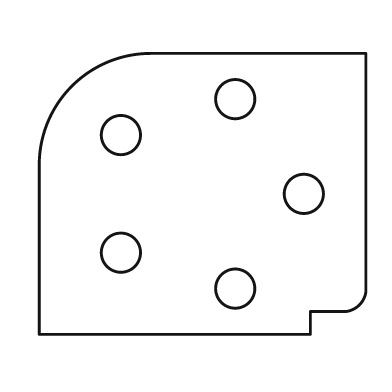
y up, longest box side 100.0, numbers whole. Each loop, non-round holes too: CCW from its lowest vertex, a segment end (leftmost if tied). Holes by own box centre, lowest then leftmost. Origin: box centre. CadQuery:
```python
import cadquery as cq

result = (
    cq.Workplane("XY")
    .moveTo(-50.0, -43.0)
    .lineTo(33.0, -43.0)
    .lineTo(33.0, -36.0)
    .lineTo(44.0, -36.0)
    .threePointArc((48.0, -34.0), (50.0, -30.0))
    .lineTo(50.0, 43.0)
    .lineTo(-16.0, 43.0)
    .threePointArc((-40.0, 33.0), (-50.0, 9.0))
    .close()
    .moveTo(10.0, -29.0)
    .circle(6.0)
    .moveTo(-25.0, -18.0)
    .circle(6.0)
    .moveTo(31.0, 0.0)
    .circle(6.0)
    .moveTo(-25.0, 18.0)
    .circle(6.0)
    .moveTo(10.0, 29.0)
    .circle(6.0)
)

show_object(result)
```